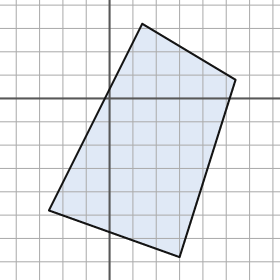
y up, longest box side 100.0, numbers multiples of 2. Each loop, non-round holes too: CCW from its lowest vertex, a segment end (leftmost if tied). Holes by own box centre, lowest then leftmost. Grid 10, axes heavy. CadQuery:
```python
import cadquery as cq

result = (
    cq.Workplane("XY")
    .moveTo(30.0, -68.0)
    .lineTo(54.0, 8.0)
    .lineTo(14.0, 32.0)
    .lineTo(-26.0, -48.0)
    .close()
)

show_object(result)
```